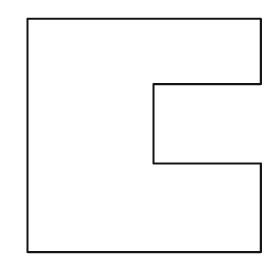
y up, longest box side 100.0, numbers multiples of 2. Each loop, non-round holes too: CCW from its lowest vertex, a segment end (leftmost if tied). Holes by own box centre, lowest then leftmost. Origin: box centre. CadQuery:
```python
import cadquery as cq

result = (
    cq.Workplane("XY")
    .moveTo(-50.0, -50.0)
    .lineTo(50.0, -50.0)
    .lineTo(50.0, -12.0)
    .lineTo(4.0, -12.0)
    .lineTo(4.0, 22.0)
    .lineTo(50.0, 22.0)
    .lineTo(50.0, 50.0)
    .lineTo(-50.0, 50.0)
    .close()
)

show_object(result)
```